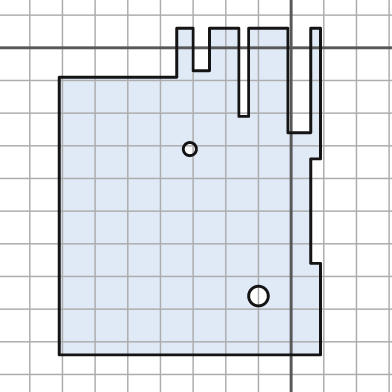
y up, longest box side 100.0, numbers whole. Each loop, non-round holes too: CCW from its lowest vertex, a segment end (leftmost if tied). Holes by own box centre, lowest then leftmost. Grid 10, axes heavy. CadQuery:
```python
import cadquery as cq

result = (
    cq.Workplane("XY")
    .moveTo(-71.0, -94.0)
    .lineTo(9.0, -94.0)
    .lineTo(9.0, -66.0)
    .lineTo(6.0, -66.0)
    .lineTo(6.0, -34.0)
    .lineTo(9.0, -34.0)
    .lineTo(9.0, 6.0)
    .lineTo(6.0, 6.0)
    .lineTo(6.0, -26.0)
    .lineTo(-1.0, -26.0)
    .lineTo(-1.0, 6.0)
    .lineTo(-13.0, 6.0)
    .lineTo(-13.0, -21.0)
    .lineTo(-16.0, -21.0)
    .lineTo(-16.0, 6.0)
    .lineTo(-25.0, 6.0)
    .lineTo(-25.0, -7.0)
    .lineTo(-30.0, -7.0)
    .lineTo(-30.0, 6.0)
    .lineTo(-35.0, 6.0)
    .lineTo(-35.0, -9.0)
    .lineTo(-71.0, -9.0)
    .close()
    .moveTo(-10.0, -76.0)
    .circle(3.0)
    .moveTo(-31.0, -31.0)
    .circle(2.0)
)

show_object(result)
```